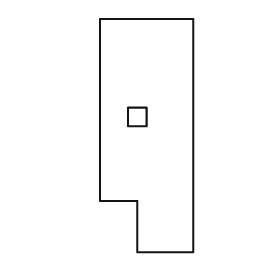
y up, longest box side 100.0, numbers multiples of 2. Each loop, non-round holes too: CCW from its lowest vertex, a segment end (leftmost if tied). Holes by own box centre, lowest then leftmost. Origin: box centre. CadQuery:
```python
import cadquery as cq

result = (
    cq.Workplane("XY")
    .moveTo(-4.0, -50.0)
    .lineTo(20.0, -50.0)
    .lineTo(20.0, 50.0)
    .lineTo(-20.0, 50.0)
    .lineTo(-20.0, -28.0)
    .lineTo(-4.0, -28.0)
    .close()
    .moveTo(-8.0, 4.0)
    .lineTo(0.0, 4.0)
    .lineTo(0.0, 12.0)
    .lineTo(-8.0, 12.0)
    .close()
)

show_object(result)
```